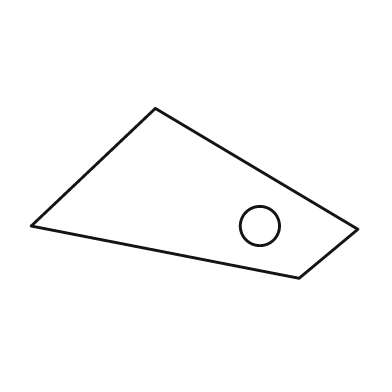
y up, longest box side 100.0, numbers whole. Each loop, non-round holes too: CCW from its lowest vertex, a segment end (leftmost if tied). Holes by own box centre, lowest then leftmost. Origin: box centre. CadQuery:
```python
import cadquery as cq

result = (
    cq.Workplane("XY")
    .moveTo(32.0, -26.0)
    .lineTo(50.0, -11.0)
    .lineTo(-12.0, 26.0)
    .lineTo(-50.0, -10.0)
    .close()
    .moveTo(20.0, -10.0)
    .circle(6.0)
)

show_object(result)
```